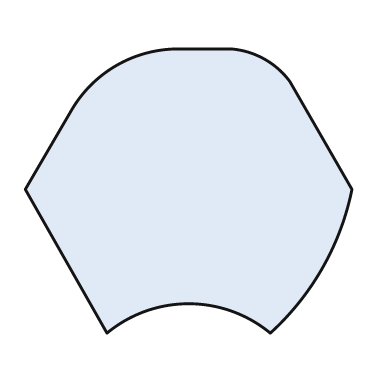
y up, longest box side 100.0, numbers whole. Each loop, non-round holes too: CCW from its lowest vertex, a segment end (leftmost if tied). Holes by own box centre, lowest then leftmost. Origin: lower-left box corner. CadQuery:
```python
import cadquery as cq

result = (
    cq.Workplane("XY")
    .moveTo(25.0, 0.0)
    .threePointArc((50.0, 9.0), (75.0, 0.0))
    .threePointArc((91.0, 20.0), (100.0, 44.0))
    .lineTo(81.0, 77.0)
    .threePointArc((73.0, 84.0), (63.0, 87.0))
    .lineTo(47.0, 87.0)
    .threePointArc((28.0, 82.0), (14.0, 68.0))
    .lineTo(0.0, 44.0)
    .close()
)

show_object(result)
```